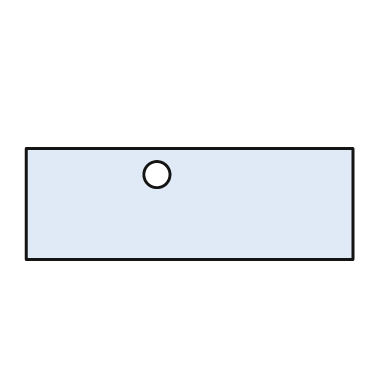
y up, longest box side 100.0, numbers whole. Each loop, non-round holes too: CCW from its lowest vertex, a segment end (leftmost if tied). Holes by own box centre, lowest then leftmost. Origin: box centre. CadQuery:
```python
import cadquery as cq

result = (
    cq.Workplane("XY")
    .moveTo(-50.0, -17.0)
    .lineTo(50.0, -17.0)
    .lineTo(50.0, 17.0)
    .lineTo(-50.0, 17.0)
    .close()
    .moveTo(-10.0, 9.0)
    .circle(4.0)
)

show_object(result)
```